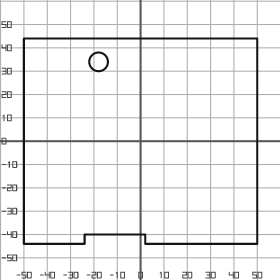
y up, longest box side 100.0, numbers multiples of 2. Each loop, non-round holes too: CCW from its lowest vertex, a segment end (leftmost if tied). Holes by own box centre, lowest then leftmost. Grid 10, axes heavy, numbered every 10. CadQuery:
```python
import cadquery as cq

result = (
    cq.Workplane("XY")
    .moveTo(-50.0, -44.0)
    .lineTo(-24.0, -44.0)
    .lineTo(-24.0, -40.0)
    .lineTo(2.0, -40.0)
    .lineTo(2.0, -44.0)
    .lineTo(50.0, -44.0)
    .lineTo(50.0, 44.0)
    .lineTo(-50.0, 44.0)
    .close()
    .moveTo(-18.0, 34.0)
    .circle(4.0)
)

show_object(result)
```